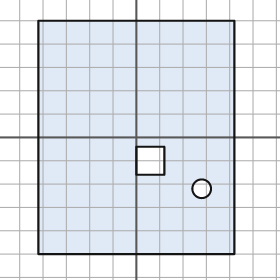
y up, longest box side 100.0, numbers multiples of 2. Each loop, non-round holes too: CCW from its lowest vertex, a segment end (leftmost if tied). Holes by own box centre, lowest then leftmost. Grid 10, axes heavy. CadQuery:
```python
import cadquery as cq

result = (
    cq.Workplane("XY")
    .moveTo(-42.0, -50.0)
    .lineTo(42.0, -50.0)
    .lineTo(42.0, 50.0)
    .lineTo(-42.0, 50.0)
    .close()
    .moveTo(28.0, -22.0)
    .circle(4.0)
    .moveTo(0.0, -16.0)
    .lineTo(12.0, -16.0)
    .lineTo(12.0, -4.0)
    .lineTo(0.0, -4.0)
    .close()
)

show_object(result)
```